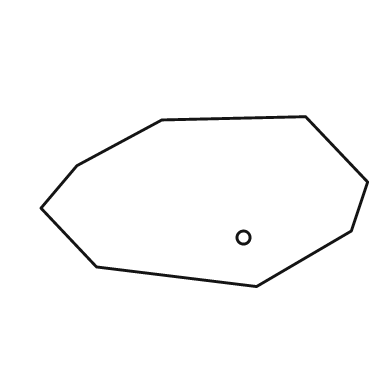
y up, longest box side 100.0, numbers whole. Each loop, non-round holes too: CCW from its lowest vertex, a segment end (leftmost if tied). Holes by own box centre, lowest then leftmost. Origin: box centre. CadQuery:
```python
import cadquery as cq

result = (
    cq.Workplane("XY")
    .moveTo(16.0, -26.0)
    .lineTo(45.0, -9.0)
    .lineTo(50.0, 6.0)
    .lineTo(31.0, 26.0)
    .lineTo(-13.0, 25.0)
    .lineTo(-39.0, 11.0)
    .lineTo(-50.0, -2.0)
    .lineTo(-33.0, -20.0)
    .close()
    .moveTo(12.0, -11.0)
    .circle(2.0)
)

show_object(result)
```